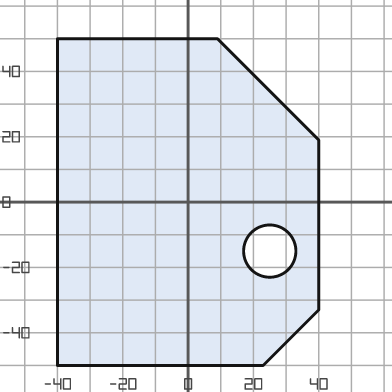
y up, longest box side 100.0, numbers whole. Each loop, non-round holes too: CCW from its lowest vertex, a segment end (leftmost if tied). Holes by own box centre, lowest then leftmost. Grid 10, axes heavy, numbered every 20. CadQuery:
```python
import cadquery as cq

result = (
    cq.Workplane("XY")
    .moveTo(-40.0, -50.0)
    .lineTo(23.0, -50.0)
    .lineTo(40.0, -33.0)
    .lineTo(40.0, 19.0)
    .lineTo(9.0, 50.0)
    .lineTo(-40.0, 50.0)
    .close()
    .moveTo(25.0, -15.0)
    .circle(8.0)
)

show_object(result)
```